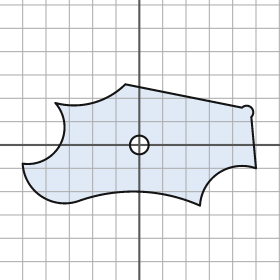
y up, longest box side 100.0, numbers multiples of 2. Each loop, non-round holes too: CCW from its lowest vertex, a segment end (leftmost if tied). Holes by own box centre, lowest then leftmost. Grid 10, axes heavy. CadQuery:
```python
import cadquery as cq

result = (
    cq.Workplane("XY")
    .moveTo(26.0, -26.0)
    .threePointArc((34.0, -12.0), (50.0, -10.0))
    .lineTo(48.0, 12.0)
    .threePointArc((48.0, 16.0), (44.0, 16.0))
    .lineTo(-6.0, 26.0)
    .threePointArc((-20.0, 18.0), (-36.0, 18.0))
    .threePointArc((-34.0, 0.0), (-50.0, -8.0))
    .threePointArc((-42.0, -22.0), (-26.0, -24.0))
    .threePointArc((0.0, -20.0), (26.0, -26.0))
    .close()
    .moveTo(0.0, 0.0)
    .circle(4.0)
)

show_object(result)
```